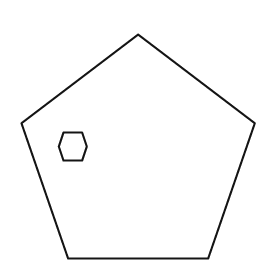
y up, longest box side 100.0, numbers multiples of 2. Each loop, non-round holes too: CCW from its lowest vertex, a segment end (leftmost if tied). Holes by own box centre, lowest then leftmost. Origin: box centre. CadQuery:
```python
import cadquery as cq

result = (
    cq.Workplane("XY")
    .moveTo(-30.0, -48.0)
    .lineTo(30.0, -48.0)
    .lineTo(50.0, 10.0)
    .lineTo(0.0, 48.0)
    .lineTo(-50.0, 10.0)
    .close()
    .moveTo(-32.0, -6.0)
    .lineTo(-24.0, -6.0)
    .lineTo(-22.0, 0.0)
    .lineTo(-24.0, 6.0)
    .lineTo(-32.0, 6.0)
    .lineTo(-34.0, 0.0)
    .close()
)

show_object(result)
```